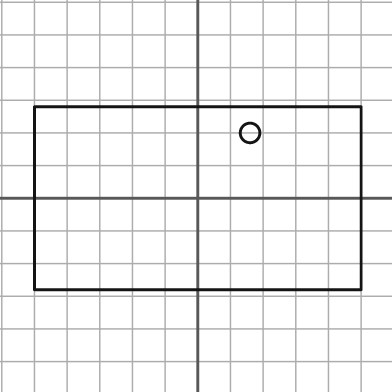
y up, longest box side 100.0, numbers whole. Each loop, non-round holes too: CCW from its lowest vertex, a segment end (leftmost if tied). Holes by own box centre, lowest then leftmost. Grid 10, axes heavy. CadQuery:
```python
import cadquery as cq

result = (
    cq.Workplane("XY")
    .moveTo(-50.0, -28.0)
    .lineTo(50.0, -28.0)
    .lineTo(50.0, 28.0)
    .lineTo(-50.0, 28.0)
    .close()
    .moveTo(16.0, 20.0)
    .circle(3.0)
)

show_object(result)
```